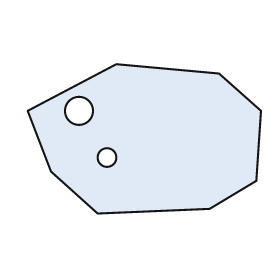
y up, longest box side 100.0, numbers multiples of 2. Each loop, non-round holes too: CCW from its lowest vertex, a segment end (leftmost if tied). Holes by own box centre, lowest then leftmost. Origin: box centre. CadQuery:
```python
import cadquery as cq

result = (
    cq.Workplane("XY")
    .moveTo(-20.0, -32.0)
    .lineTo(28.0, -30.0)
    .lineTo(48.0, -18.0)
    .lineTo(50.0, 12.0)
    .lineTo(32.0, 28.0)
    .lineTo(-12.0, 32.0)
    .lineTo(-50.0, 12.0)
    .lineTo(-40.0, -14.0)
    .close()
    .moveTo(-16.0, -8.0)
    .circle(4.0)
    .moveTo(-28.0, 12.0)
    .circle(6.0)
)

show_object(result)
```